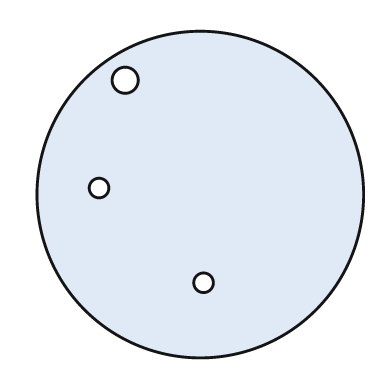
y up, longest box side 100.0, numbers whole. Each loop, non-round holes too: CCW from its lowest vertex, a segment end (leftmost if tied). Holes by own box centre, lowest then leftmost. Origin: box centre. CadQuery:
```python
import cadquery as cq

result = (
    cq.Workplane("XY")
    .moveTo(0.0, 0.0)
    .circle(50.0)
    .moveTo(1.0, -27.0)
    .circle(3.0)
    .moveTo(-31.0, 2.0)
    .circle(3.0)
    .moveTo(-23.0, 35.0)
    .circle(4.0)
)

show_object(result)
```